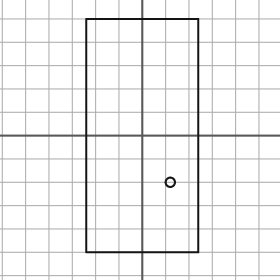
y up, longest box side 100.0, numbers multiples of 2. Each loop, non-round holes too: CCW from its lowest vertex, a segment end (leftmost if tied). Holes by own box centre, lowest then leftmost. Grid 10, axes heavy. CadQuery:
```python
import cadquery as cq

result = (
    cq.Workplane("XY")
    .moveTo(-24.0, -50.0)
    .lineTo(24.0, -50.0)
    .lineTo(24.0, 50.0)
    .lineTo(-24.0, 50.0)
    .close()
    .moveTo(12.0, -20.0)
    .circle(2.0)
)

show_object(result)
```